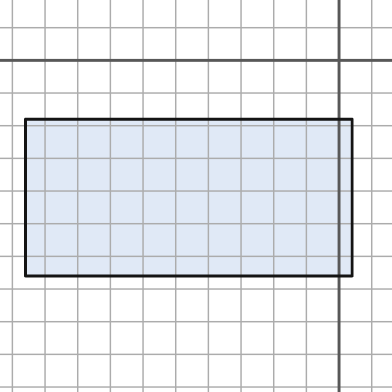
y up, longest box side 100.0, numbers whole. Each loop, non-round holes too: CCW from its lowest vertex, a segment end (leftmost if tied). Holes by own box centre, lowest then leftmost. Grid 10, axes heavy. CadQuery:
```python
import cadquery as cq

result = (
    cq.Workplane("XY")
    .moveTo(-96.0, -66.0)
    .lineTo(4.0, -66.0)
    .lineTo(4.0, -18.0)
    .lineTo(-96.0, -18.0)
    .close()
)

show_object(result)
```